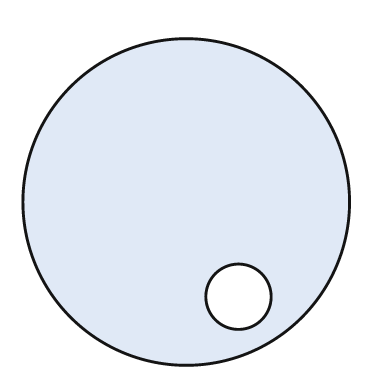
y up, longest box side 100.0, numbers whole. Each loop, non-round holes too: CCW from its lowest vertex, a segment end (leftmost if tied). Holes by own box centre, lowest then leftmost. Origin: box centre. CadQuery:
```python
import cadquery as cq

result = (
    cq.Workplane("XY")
    .moveTo(0.0, 0.0)
    .circle(50.0)
    .moveTo(16.0, -29.0)
    .circle(10.0)
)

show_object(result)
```